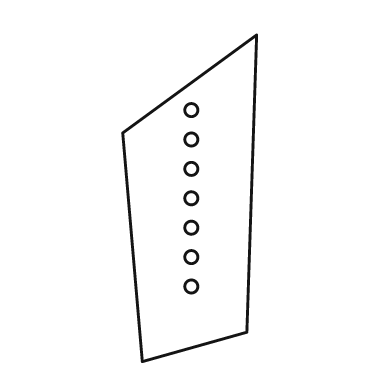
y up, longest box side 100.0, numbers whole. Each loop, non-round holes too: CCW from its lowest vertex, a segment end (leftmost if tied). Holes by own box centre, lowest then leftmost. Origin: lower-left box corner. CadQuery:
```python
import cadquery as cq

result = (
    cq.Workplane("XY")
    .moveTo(6.0, 0.0)
    .lineTo(38.0, 9.0)
    .lineTo(41.0, 100.0)
    .lineTo(0.0, 70.0)
    .close()
    .moveTo(21.0, 23.0)
    .circle(2.0)
    .moveTo(21.0, 32.0)
    .circle(2.0)
    .moveTo(21.0, 41.0)
    .circle(2.0)
    .moveTo(21.0, 50.0)
    .circle(2.0)
    .moveTo(21.0, 59.0)
    .circle(2.0)
    .moveTo(21.0, 68.0)
    .circle(2.0)
    .moveTo(21.0, 77.0)
    .circle(2.0)
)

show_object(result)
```